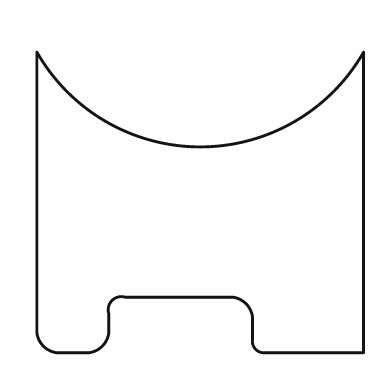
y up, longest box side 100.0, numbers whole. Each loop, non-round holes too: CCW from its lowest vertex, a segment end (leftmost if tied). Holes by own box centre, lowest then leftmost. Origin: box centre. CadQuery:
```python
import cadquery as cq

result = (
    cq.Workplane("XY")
    .moveTo(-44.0, -46.0)
    .lineTo(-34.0, -46.0)
    .threePointArc((-30.0, -44.0), (-28.0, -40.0))
    .lineTo(-28.0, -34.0)
    .threePointArc((-27.0, -30.0), (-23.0, -29.0))
    .lineTo(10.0, -29.0)
    .threePointArc((14.0, -31.0), (16.0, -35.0))
    .lineTo(16.0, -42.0)
    .threePointArc((17.0, -45.0), (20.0, -46.0))
    .lineTo(50.0, -46.0)
    .lineTo(50.0, 46.0)
    .threePointArc((0.0, 17.0), (-50.0, 46.0))
    .lineTo(-50.0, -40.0)
    .threePointArc((-48.0, -44.0), (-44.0, -46.0))
    .close()
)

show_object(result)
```